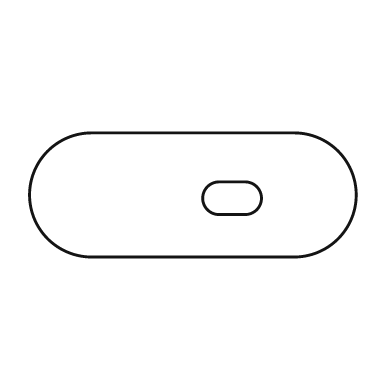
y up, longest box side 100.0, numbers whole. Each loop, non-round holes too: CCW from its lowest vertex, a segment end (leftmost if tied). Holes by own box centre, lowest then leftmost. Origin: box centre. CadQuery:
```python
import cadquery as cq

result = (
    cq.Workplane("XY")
    .moveTo(-31.0, -19.0)
    .lineTo(31.0, -19.0)
    .threePointArc((50.0, 0.0), (31.0, 19.0))
    .lineTo(-31.0, 19.0)
    .threePointArc((-50.0, 0.0), (-31.0, -19.0))
    .close()
    .moveTo(8.0, -6.0)
    .lineTo(16.0, -6.0)
    .threePointArc((21.0, -1.0), (16.0, 4.0))
    .lineTo(8.0, 4.0)
    .threePointArc((3.0, -1.0), (8.0, -6.0))
    .close()
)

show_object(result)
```